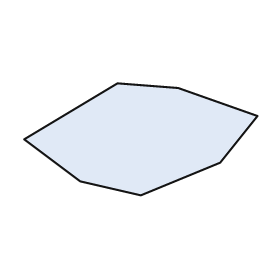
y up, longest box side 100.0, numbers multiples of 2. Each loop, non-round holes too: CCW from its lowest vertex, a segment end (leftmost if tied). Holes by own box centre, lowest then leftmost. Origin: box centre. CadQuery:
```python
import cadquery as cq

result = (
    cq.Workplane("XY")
    .moveTo(0.0, -24.0)
    .lineTo(34.0, -10.0)
    .lineTo(50.0, 10.0)
    .lineTo(16.0, 22.0)
    .lineTo(-10.0, 24.0)
    .lineTo(-50.0, 0.0)
    .lineTo(-26.0, -18.0)
    .close()
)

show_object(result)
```